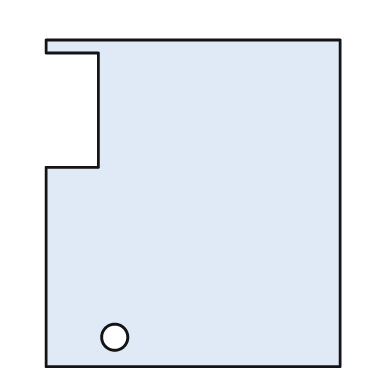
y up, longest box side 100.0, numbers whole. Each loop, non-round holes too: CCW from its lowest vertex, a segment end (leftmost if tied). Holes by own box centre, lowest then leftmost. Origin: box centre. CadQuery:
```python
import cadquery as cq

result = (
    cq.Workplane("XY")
    .moveTo(-45.0, -50.0)
    .lineTo(45.0, -50.0)
    .lineTo(45.0, 50.0)
    .lineTo(-45.0, 50.0)
    .lineTo(-45.0, 46.0)
    .lineTo(-29.0, 46.0)
    .lineTo(-29.0, 11.0)
    .lineTo(-45.0, 11.0)
    .close()
    .moveTo(-24.0, -41.0)
    .circle(4.0)
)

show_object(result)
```